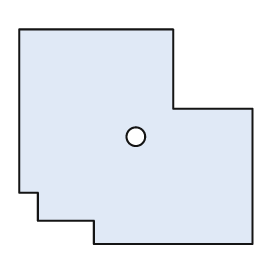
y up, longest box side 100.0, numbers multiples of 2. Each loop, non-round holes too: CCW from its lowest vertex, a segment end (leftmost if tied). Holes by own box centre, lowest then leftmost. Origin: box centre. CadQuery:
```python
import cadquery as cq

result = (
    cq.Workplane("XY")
    .moveTo(-18.0, -46.0)
    .lineTo(50.0, -46.0)
    .lineTo(50.0, 12.0)
    .lineTo(16.0, 12.0)
    .lineTo(16.0, 46.0)
    .lineTo(-50.0, 46.0)
    .lineTo(-50.0, -24.0)
    .lineTo(-42.0, -24.0)
    .lineTo(-42.0, -36.0)
    .lineTo(-18.0, -36.0)
    .close()
    .moveTo(0.0, 0.0)
    .circle(4.0)
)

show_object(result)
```